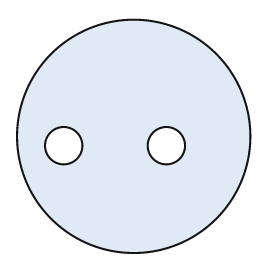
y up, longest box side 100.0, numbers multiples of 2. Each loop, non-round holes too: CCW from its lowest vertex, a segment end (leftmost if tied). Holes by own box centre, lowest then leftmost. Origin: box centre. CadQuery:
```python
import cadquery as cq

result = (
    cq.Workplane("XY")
    .moveTo(0.0, 0.0)
    .circle(50.0)
    .moveTo(-30.0, -4.0)
    .circle(8.0)
    .moveTo(14.0, -4.0)
    .circle(8.0)
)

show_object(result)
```